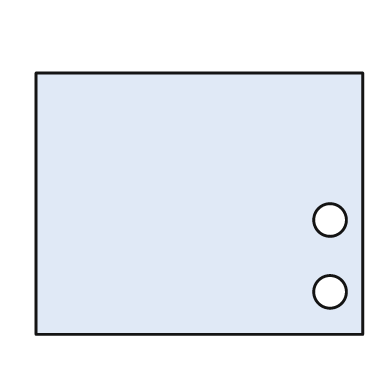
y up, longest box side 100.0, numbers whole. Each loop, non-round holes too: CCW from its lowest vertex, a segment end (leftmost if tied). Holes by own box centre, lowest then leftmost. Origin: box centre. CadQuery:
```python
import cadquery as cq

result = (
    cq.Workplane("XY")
    .moveTo(-50.0, -40.0)
    .lineTo(50.0, -40.0)
    .lineTo(50.0, 40.0)
    .lineTo(-50.0, 40.0)
    .close()
    .moveTo(40.0, -27.0)
    .circle(5.0)
    .moveTo(40.0, -5.0)
    .circle(5.0)
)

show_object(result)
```